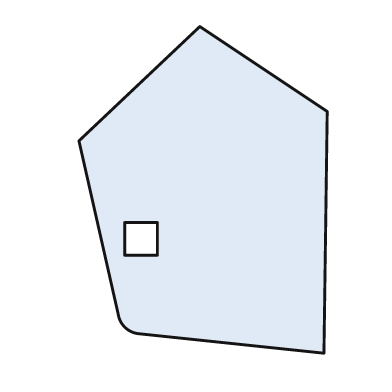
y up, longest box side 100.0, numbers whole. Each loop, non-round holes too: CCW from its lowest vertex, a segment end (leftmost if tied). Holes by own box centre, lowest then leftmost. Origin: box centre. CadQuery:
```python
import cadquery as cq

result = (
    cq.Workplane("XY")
    .moveTo(37.0, -50.0)
    .lineTo(38.0, 24.0)
    .lineTo(-1.0, 50.0)
    .lineTo(-38.0, 15.0)
    .lineTo(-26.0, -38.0)
    .threePointArc((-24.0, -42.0), (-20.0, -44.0))
    .close()
    .moveTo(-24.0, -20.0)
    .lineTo(-14.0, -20.0)
    .lineTo(-14.0, -10.0)
    .lineTo(-24.0, -10.0)
    .close()
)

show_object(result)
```